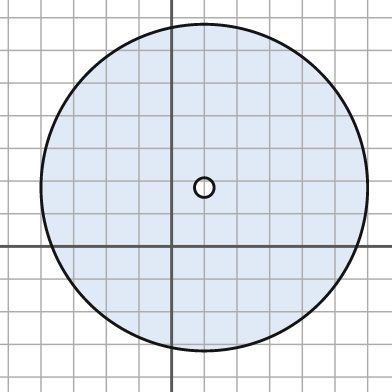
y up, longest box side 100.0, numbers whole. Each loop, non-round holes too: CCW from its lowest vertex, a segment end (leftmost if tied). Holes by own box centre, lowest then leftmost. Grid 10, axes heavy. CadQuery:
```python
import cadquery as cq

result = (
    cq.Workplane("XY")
    .moveTo(10.0, 18.0)
    .circle(50.0)
    .moveTo(10.0, 18.0)
    .circle(3.0)
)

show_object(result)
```